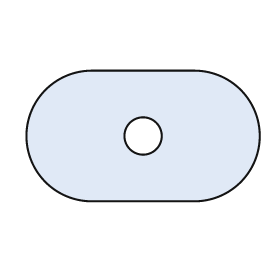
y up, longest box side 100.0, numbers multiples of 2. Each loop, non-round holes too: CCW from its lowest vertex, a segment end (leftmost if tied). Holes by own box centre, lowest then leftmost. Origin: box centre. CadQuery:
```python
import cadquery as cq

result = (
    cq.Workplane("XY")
    .moveTo(-22.0, -28.0)
    .lineTo(22.0, -28.0)
    .threePointArc((50.0, 0.0), (22.0, 28.0))
    .lineTo(-22.0, 28.0)
    .threePointArc((-50.0, 0.0), (-22.0, -28.0))
    .close()
    .moveTo(0.0, 0.0)
    .circle(8.0)
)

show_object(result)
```